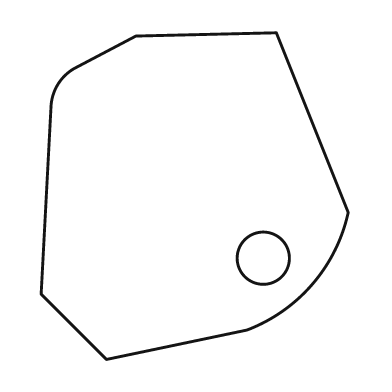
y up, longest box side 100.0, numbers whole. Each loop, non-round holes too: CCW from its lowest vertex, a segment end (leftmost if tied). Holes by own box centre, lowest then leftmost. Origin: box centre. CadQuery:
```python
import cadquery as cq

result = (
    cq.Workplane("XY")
    .moveTo(-27.0, -50.0)
    .lineTo(16.0, -41.0)
    .threePointArc((36.0, -27.0), (47.0, -5.0))
    .lineTo(25.0, 50.0)
    .lineTo(-18.0, 49.0)
    .lineTo(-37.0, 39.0)
    .threePointArc((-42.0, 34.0), (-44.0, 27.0))
    .lineTo(-47.0, -30.0)
    .close()
    .moveTo(21.0, -19.0)
    .circle(8.0)
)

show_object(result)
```